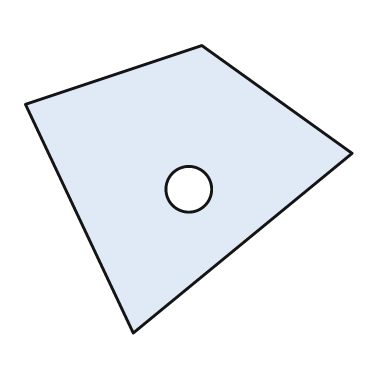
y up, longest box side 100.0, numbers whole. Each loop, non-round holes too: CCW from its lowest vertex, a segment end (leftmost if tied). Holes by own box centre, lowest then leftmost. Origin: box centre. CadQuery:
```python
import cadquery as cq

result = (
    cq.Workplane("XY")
    .moveTo(-17.0, -44.0)
    .lineTo(50.0, 11.0)
    .lineTo(4.0, 44.0)
    .lineTo(-50.0, 26.0)
    .close()
    .moveTo(0.0, 0.0)
    .circle(7.0)
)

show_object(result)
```